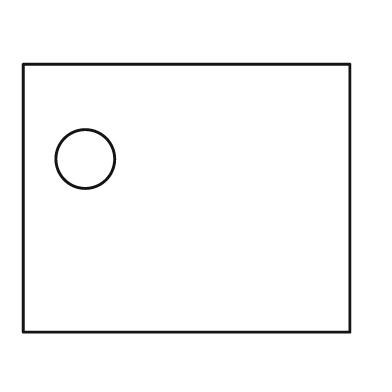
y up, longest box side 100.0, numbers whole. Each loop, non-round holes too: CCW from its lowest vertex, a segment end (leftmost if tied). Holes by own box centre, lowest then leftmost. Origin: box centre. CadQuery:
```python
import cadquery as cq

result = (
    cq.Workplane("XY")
    .moveTo(-50.0, -41.0)
    .lineTo(50.0, -41.0)
    .lineTo(50.0, 41.0)
    .lineTo(-50.0, 41.0)
    .close()
    .moveTo(-31.0, 12.0)
    .circle(9.0)
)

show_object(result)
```